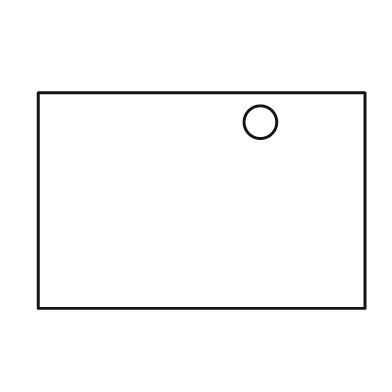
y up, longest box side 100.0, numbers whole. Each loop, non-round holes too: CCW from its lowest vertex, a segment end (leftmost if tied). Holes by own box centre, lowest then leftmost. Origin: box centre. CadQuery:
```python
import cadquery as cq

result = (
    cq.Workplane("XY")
    .moveTo(-50.0, -33.0)
    .lineTo(50.0, -33.0)
    .lineTo(50.0, 33.0)
    .lineTo(-50.0, 33.0)
    .close()
    .moveTo(18.0, 24.0)
    .circle(5.0)
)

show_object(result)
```